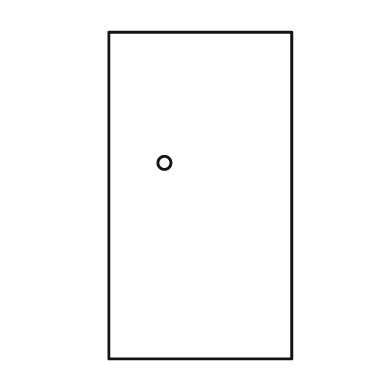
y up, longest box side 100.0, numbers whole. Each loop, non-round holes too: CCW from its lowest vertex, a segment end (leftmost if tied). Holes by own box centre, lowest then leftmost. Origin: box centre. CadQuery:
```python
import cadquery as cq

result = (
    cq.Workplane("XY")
    .moveTo(-28.0, -50.0)
    .lineTo(28.0, -50.0)
    .lineTo(28.0, 50.0)
    .lineTo(-28.0, 50.0)
    .close()
    .moveTo(-11.0, 10.0)
    .circle(2.0)
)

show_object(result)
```